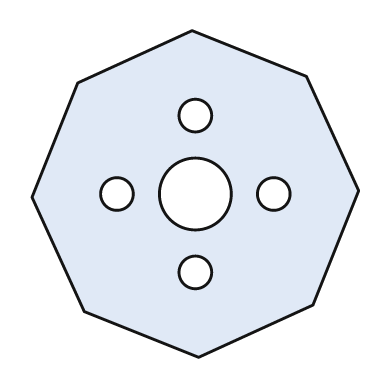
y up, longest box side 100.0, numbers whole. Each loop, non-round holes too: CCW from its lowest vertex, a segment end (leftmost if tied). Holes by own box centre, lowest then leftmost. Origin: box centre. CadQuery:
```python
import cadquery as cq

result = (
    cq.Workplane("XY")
    .moveTo(1.0, -50.0)
    .lineTo(36.0, -34.0)
    .lineTo(50.0, 1.0)
    .lineTo(34.0, 36.0)
    .lineTo(-1.0, 50.0)
    .lineTo(-36.0, 34.0)
    .lineTo(-50.0, -1.0)
    .lineTo(-34.0, -36.0)
    .close()
    .moveTo(0.0, -24.0)
    .circle(5.0)
    .moveTo(-24.0, 0.0)
    .circle(5.0)
    .moveTo(0.0, 0.0)
    .circle(11.0)
    .moveTo(24.0, 0.0)
    .circle(5.0)
    .moveTo(0.0, 24.0)
    .circle(5.0)
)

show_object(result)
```